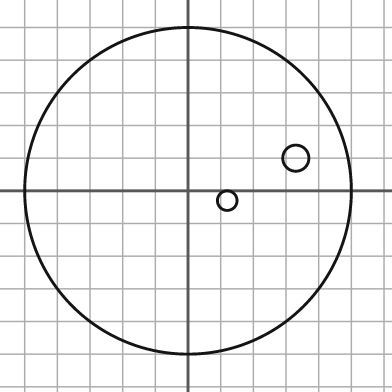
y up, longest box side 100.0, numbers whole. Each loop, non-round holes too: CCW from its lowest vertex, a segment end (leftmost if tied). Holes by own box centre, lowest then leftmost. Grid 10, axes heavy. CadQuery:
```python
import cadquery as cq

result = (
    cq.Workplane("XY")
    .moveTo(0.0, 0.0)
    .circle(50.0)
    .moveTo(12.0, -3.0)
    .circle(3.0)
    .moveTo(33.0, 10.0)
    .circle(4.0)
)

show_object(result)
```